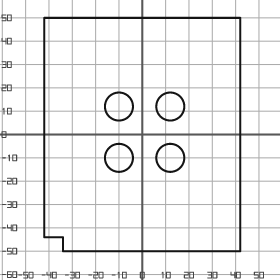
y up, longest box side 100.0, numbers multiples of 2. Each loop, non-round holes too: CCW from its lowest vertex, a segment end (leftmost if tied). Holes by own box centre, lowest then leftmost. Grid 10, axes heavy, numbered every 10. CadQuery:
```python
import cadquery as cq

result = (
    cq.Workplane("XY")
    .moveTo(-34.0, -50.0)
    .lineTo(42.0, -50.0)
    .lineTo(42.0, 50.0)
    .lineTo(-42.0, 50.0)
    .lineTo(-42.0, -44.0)
    .lineTo(-34.0, -44.0)
    .close()
    .moveTo(-10.0, -10.0)
    .circle(6.0)
    .moveTo(12.0, -10.0)
    .circle(6.0)
    .moveTo(-10.0, 12.0)
    .circle(6.0)
    .moveTo(12.0, 12.0)
    .circle(6.0)
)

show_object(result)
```